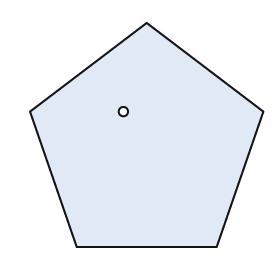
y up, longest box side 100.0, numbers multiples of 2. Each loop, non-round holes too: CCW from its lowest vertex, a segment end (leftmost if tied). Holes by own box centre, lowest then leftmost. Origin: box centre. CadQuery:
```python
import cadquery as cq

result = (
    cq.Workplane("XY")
    .moveTo(-30.0, -48.0)
    .lineTo(30.0, -48.0)
    .lineTo(50.0, 10.0)
    .lineTo(0.0, 48.0)
    .lineTo(-50.0, 10.0)
    .close()
    .moveTo(-10.0, 10.0)
    .circle(2.0)
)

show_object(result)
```